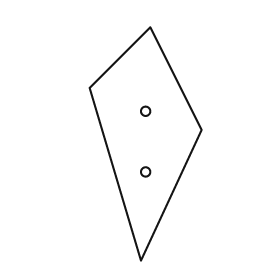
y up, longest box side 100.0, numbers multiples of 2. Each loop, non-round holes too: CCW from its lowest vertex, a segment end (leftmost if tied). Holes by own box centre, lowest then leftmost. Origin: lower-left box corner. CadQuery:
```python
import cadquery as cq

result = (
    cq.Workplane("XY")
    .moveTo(22.0, 0.0)
    .lineTo(48.0, 56.0)
    .lineTo(26.0, 100.0)
    .lineTo(0.0, 74.0)
    .close()
    .moveTo(24.0, 38.0)
    .circle(2.0)
    .moveTo(24.0, 64.0)
    .circle(2.0)
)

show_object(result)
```